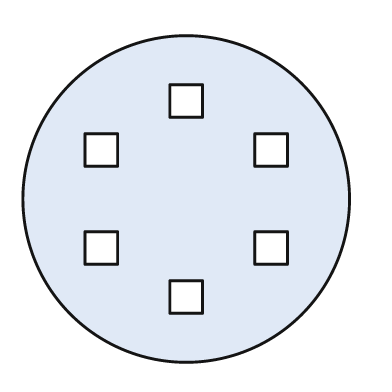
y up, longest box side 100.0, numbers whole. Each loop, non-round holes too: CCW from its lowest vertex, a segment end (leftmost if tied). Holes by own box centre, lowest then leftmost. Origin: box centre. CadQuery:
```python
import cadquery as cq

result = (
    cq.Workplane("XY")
    .moveTo(0.0, 0.0)
    .circle(50.0)
    .moveTo(-5.0, -35.0)
    .lineTo(5.0, -35.0)
    .lineTo(5.0, -25.0)
    .lineTo(-5.0, -25.0)
    .close()
    .moveTo(-31.0, -20.0)
    .lineTo(-21.0, -20.0)
    .lineTo(-21.0, -10.0)
    .lineTo(-31.0, -10.0)
    .close()
    .moveTo(21.0, -20.0)
    .lineTo(31.0, -20.0)
    .lineTo(31.0, -10.0)
    .lineTo(21.0, -10.0)
    .close()
    .moveTo(-31.0, 10.0)
    .lineTo(-21.0, 10.0)
    .lineTo(-21.0, 20.0)
    .lineTo(-31.0, 20.0)
    .close()
    .moveTo(21.0, 10.0)
    .lineTo(31.0, 10.0)
    .lineTo(31.0, 20.0)
    .lineTo(21.0, 20.0)
    .close()
    .moveTo(-5.0, 25.0)
    .lineTo(5.0, 25.0)
    .lineTo(5.0, 35.0)
    .lineTo(-5.0, 35.0)
    .close()
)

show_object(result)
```